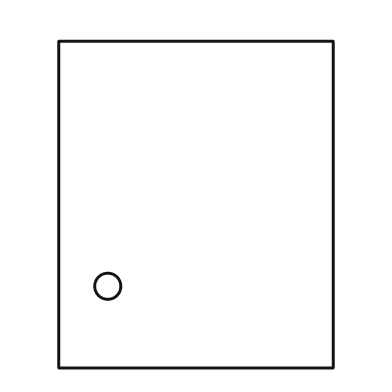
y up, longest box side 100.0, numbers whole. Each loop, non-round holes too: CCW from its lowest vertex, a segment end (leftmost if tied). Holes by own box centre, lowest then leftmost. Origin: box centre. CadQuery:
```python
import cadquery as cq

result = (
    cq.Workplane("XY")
    .moveTo(-42.0, -50.0)
    .lineTo(42.0, -50.0)
    .lineTo(42.0, 50.0)
    .lineTo(-42.0, 50.0)
    .close()
    .moveTo(-27.0, -25.0)
    .circle(4.0)
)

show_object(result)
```